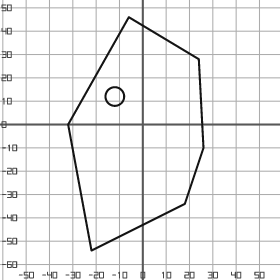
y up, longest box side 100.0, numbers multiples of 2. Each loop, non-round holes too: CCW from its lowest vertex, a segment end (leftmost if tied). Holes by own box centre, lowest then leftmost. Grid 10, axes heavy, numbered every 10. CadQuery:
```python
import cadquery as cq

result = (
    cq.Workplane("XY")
    .moveTo(-22.0, -54.0)
    .lineTo(18.0, -34.0)
    .lineTo(26.0, -10.0)
    .lineTo(24.0, 28.0)
    .lineTo(-6.0, 46.0)
    .lineTo(-32.0, 0.0)
    .close()
    .moveTo(-12.0, 12.0)
    .circle(4.0)
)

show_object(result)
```